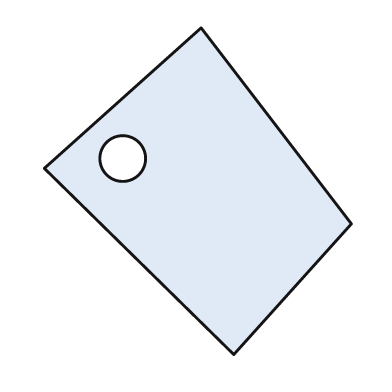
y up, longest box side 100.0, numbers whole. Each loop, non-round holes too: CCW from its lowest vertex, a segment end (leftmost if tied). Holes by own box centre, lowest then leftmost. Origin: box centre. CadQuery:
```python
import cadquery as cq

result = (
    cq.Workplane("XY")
    .moveTo(11.0, -50.0)
    .lineTo(47.0, -10.0)
    .lineTo(1.0, 50.0)
    .lineTo(-47.0, 7.0)
    .close()
    .moveTo(-23.0, 10.0)
    .circle(7.0)
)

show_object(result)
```